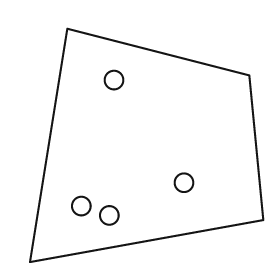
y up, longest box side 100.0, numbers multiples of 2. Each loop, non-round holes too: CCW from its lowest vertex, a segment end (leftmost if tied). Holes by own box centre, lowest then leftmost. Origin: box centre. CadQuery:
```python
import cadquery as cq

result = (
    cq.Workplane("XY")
    .moveTo(-50.0, -50.0)
    .lineTo(50.0, -32.0)
    .lineTo(44.0, 30.0)
    .lineTo(-34.0, 50.0)
    .close()
    .moveTo(-16.0, -30.0)
    .circle(4.0)
    .moveTo(-28.0, -26.0)
    .circle(4.0)
    .moveTo(16.0, -16.0)
    .circle(4.0)
    .moveTo(-14.0, 28.0)
    .circle(4.0)
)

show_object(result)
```